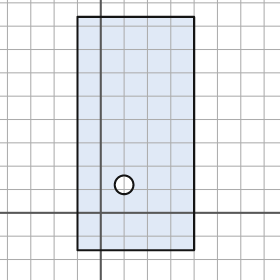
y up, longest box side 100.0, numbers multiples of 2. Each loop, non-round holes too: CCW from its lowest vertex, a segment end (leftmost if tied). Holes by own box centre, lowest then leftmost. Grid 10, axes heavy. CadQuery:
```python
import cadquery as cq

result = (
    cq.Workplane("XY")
    .moveTo(-10.0, -16.0)
    .lineTo(40.0, -16.0)
    .lineTo(40.0, 84.0)
    .lineTo(-10.0, 84.0)
    .close()
    .moveTo(10.0, 12.0)
    .circle(4.0)
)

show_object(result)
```